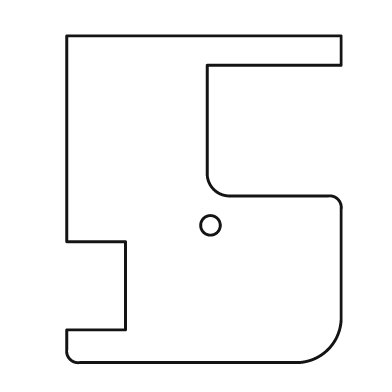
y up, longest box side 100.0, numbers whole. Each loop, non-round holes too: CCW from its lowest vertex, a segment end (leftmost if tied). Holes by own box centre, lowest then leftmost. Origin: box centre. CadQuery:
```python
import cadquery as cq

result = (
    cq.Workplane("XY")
    .moveTo(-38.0, -50.0)
    .lineTo(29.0, -50.0)
    .threePointArc((38.0, -46.0), (42.0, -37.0))
    .lineTo(42.0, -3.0)
    .threePointArc((41.0, 0.0), (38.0, 1.0))
    .lineTo(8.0, 1.0)
    .threePointArc((3.0, 3.0), (1.0, 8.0))
    .lineTo(1.0, 41.0)
    .lineTo(42.0, 41.0)
    .lineTo(42.0, 50.0)
    .lineTo(-42.0, 50.0)
    .lineTo(-42.0, -13.0)
    .lineTo(-24.0, -13.0)
    .lineTo(-24.0, -40.0)
    .lineTo(-42.0, -40.0)
    .lineTo(-42.0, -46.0)
    .threePointArc((-41.0, -49.0), (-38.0, -50.0))
    .close()
    .moveTo(2.0, -8.0)
    .circle(3.0)
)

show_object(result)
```